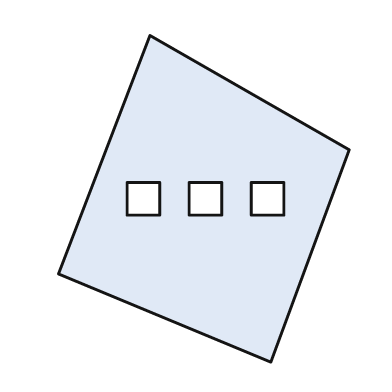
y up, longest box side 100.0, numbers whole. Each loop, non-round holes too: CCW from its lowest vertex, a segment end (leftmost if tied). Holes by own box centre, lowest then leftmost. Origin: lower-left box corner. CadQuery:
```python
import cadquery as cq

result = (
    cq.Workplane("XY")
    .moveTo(65.0, 0.0)
    .lineTo(89.0, 65.0)
    .lineTo(28.0, 100.0)
    .lineTo(0.0, 27.0)
    .close()
    .moveTo(21.0, 45.0)
    .lineTo(31.0, 45.0)
    .lineTo(31.0, 55.0)
    .lineTo(21.0, 55.0)
    .close()
    .moveTo(40.0, 45.0)
    .lineTo(50.0, 45.0)
    .lineTo(50.0, 55.0)
    .lineTo(40.0, 55.0)
    .close()
    .moveTo(59.0, 45.0)
    .lineTo(69.0, 45.0)
    .lineTo(69.0, 55.0)
    .lineTo(59.0, 55.0)
    .close()
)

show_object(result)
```